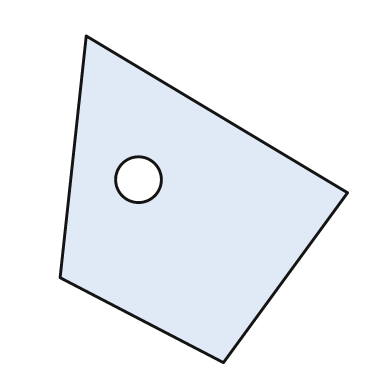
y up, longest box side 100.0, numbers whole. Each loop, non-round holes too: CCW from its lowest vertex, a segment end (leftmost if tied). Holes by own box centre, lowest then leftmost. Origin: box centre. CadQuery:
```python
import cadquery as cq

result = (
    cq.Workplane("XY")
    .moveTo(6.0, -50.0)
    .lineTo(44.0, 2.0)
    .lineTo(-36.0, 50.0)
    .lineTo(-44.0, -24.0)
    .close()
    .moveTo(-20.0, 6.0)
    .circle(7.0)
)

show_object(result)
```